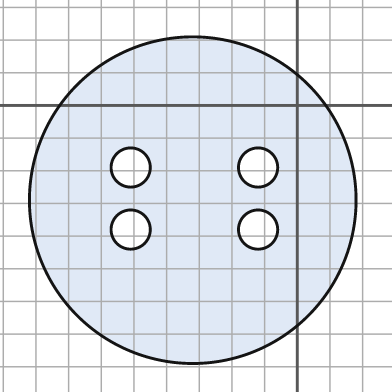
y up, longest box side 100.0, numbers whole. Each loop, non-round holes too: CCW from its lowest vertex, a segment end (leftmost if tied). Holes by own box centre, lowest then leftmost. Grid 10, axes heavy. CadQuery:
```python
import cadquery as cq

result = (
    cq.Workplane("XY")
    .moveTo(-32.0, -29.0)
    .circle(50.0)
    .moveTo(-51.0, -38.0)
    .circle(6.0)
    .moveTo(-12.0, -38.0)
    .circle(6.0)
    .moveTo(-51.0, -19.0)
    .circle(6.0)
    .moveTo(-12.0, -19.0)
    .circle(6.0)
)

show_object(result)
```